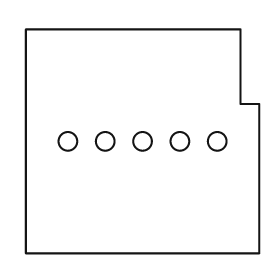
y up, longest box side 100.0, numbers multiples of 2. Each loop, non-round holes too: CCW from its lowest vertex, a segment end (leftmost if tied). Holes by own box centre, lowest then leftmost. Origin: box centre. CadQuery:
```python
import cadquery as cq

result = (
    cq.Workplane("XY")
    .moveTo(-50.0, -48.0)
    .lineTo(50.0, -48.0)
    .lineTo(50.0, 16.0)
    .lineTo(42.0, 16.0)
    .lineTo(42.0, 48.0)
    .lineTo(-50.0, 48.0)
    .close()
    .moveTo(-32.0, 0.0)
    .circle(4.0)
    .moveTo(-16.0, 0.0)
    .circle(4.0)
    .moveTo(0.0, 0.0)
    .circle(4.0)
    .moveTo(16.0, 0.0)
    .circle(4.0)
    .moveTo(32.0, 0.0)
    .circle(4.0)
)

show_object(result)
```